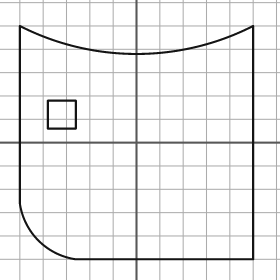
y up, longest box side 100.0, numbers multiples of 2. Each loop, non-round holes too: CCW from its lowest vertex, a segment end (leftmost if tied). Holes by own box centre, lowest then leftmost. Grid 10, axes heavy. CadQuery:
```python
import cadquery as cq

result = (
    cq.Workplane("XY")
    .moveTo(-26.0, -50.0)
    .lineTo(50.0, -50.0)
    .lineTo(50.0, 50.0)
    .threePointArc((0.0, 38.0), (-50.0, 50.0))
    .lineTo(-50.0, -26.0)
    .threePointArc((-42.0, -42.0), (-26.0, -50.0))
    .close()
    .moveTo(-38.0, 6.0)
    .lineTo(-26.0, 6.0)
    .lineTo(-26.0, 18.0)
    .lineTo(-38.0, 18.0)
    .close()
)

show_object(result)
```